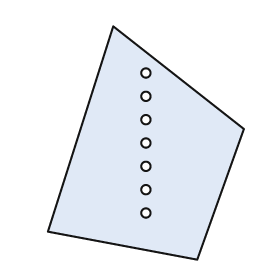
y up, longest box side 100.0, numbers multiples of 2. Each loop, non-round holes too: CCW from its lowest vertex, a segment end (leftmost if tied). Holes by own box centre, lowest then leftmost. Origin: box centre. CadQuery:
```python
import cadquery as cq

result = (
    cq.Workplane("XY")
    .moveTo(22.0, -50.0)
    .lineTo(42.0, 6.0)
    .lineTo(-14.0, 50.0)
    .lineTo(-42.0, -38.0)
    .close()
    .moveTo(0.0, -30.0)
    .circle(2.0)
    .moveTo(0.0, -20.0)
    .circle(2.0)
    .moveTo(0.0, -10.0)
    .circle(2.0)
    .moveTo(0.0, 0.0)
    .circle(2.0)
    .moveTo(0.0, 10.0)
    .circle(2.0)
    .moveTo(0.0, 20.0)
    .circle(2.0)
    .moveTo(0.0, 30.0)
    .circle(2.0)
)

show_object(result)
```